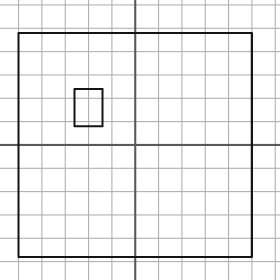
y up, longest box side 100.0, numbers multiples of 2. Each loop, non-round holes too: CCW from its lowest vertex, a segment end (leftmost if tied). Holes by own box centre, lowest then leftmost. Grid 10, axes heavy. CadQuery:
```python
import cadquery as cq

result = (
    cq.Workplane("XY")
    .moveTo(-50.0, -48.0)
    .lineTo(50.0, -48.0)
    .lineTo(50.0, 48.0)
    .lineTo(-50.0, 48.0)
    .close()
    .moveTo(-26.0, 8.0)
    .lineTo(-14.0, 8.0)
    .lineTo(-14.0, 24.0)
    .lineTo(-26.0, 24.0)
    .close()
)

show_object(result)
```